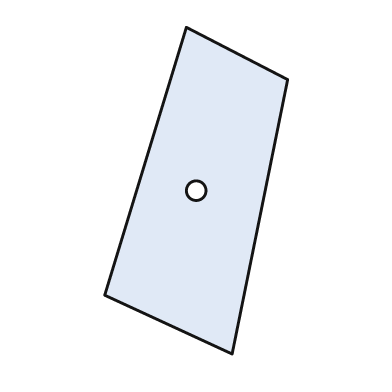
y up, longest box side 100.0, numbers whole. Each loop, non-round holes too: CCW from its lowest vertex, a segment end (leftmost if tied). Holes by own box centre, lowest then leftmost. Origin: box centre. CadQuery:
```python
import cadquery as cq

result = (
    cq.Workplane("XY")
    .moveTo(11.0, -50.0)
    .lineTo(28.0, 34.0)
    .lineTo(-3.0, 50.0)
    .lineTo(-28.0, -32.0)
    .close()
    .moveTo(0.0, 0.0)
    .circle(3.0)
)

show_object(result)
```